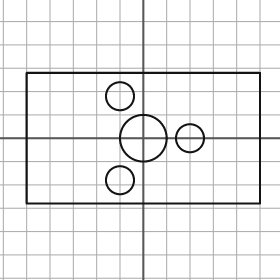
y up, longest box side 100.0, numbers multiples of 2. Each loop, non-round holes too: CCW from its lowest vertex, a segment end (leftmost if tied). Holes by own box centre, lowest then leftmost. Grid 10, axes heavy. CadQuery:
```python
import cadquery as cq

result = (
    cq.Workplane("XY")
    .moveTo(-50.0, -28.0)
    .lineTo(50.0, -28.0)
    .lineTo(50.0, 28.0)
    .lineTo(-50.0, 28.0)
    .close()
    .moveTo(-10.0, -18.0)
    .circle(6.0)
    .moveTo(0.0, 0.0)
    .circle(10.0)
    .moveTo(20.0, 0.0)
    .circle(6.0)
    .moveTo(-10.0, 18.0)
    .circle(6.0)
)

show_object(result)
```